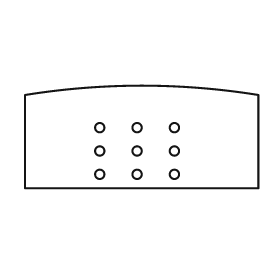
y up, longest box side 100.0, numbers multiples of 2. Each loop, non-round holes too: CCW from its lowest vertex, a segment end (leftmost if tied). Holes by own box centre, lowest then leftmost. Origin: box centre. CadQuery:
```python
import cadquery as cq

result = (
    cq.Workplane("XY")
    .moveTo(-50.0, -22.0)
    .lineTo(50.0, -22.0)
    .lineTo(50.0, 18.0)
    .threePointArc((0.0, 22.0), (-50.0, 18.0))
    .close()
    .moveTo(-18.0, -16.0)
    .circle(2.0)
    .moveTo(-2.0, -16.0)
    .circle(2.0)
    .moveTo(14.0, -16.0)
    .circle(2.0)
    .moveTo(-18.0, -6.0)
    .circle(2.0)
    .moveTo(-2.0, -6.0)
    .circle(2.0)
    .moveTo(14.0, -6.0)
    .circle(2.0)
    .moveTo(-18.0, 4.0)
    .circle(2.0)
    .moveTo(-2.0, 4.0)
    .circle(2.0)
    .moveTo(14.0, 4.0)
    .circle(2.0)
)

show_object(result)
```